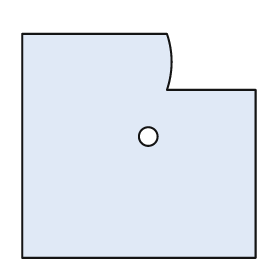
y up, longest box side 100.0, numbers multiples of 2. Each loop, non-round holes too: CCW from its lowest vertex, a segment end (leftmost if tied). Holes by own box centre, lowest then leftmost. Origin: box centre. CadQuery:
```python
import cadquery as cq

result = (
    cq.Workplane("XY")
    .moveTo(-50.0, -48.0)
    .lineTo(50.0, -48.0)
    .lineTo(50.0, 24.0)
    .lineTo(12.0, 24.0)
    .threePointArc((14.0, 36.0), (12.0, 48.0))
    .lineTo(-50.0, 48.0)
    .close()
    .moveTo(4.0, 4.0)
    .circle(4.0)
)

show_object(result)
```